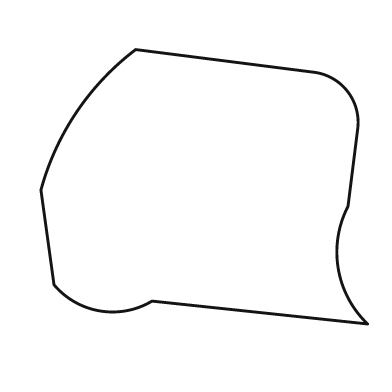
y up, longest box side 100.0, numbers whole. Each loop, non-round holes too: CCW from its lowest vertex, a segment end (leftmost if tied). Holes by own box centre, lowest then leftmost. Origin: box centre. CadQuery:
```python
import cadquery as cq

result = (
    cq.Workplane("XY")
    .moveTo(50.0, -42.0)
    .threePointArc((41.0, -25.0), (44.0, -6.0))
    .lineTo(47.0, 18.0)
    .threePointArc((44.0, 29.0), (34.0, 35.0))
    .lineTo(-21.0, 42.0)
    .threePointArc((-39.0, 23.0), (-50.0, -1.0))
    .lineTo(-46.0, -30.0)
    .threePointArc((-32.0, -38.0), (-16.0, -35.0))
    .close()
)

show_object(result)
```